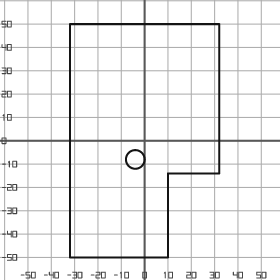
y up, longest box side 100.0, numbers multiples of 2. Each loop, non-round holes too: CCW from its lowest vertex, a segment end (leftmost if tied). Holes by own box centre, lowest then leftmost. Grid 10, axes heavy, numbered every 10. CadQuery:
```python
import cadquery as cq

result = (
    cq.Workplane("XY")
    .moveTo(-32.0, -50.0)
    .lineTo(10.0, -50.0)
    .lineTo(10.0, -14.0)
    .lineTo(32.0, -14.0)
    .lineTo(32.0, 50.0)
    .lineTo(-32.0, 50.0)
    .close()
    .moveTo(-4.0, -8.0)
    .circle(4.0)
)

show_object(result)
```